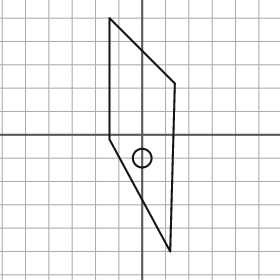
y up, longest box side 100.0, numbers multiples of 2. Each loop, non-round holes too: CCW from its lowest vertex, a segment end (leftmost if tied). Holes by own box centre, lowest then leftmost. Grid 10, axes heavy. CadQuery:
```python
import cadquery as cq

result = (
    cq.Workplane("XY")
    .moveTo(12.0, -50.0)
    .lineTo(14.0, 22.0)
    .lineTo(-14.0, 50.0)
    .lineTo(-14.0, -2.0)
    .close()
    .moveTo(0.0, -10.0)
    .circle(4.0)
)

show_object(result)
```